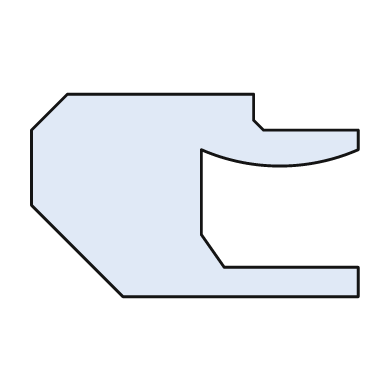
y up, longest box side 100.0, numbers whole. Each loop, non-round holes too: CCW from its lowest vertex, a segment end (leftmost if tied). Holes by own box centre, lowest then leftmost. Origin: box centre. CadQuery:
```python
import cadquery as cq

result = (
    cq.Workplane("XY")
    .moveTo(-22.0, -31.0)
    .lineTo(50.0, -31.0)
    .lineTo(50.0, -22.0)
    .lineTo(9.0, -22.0)
    .lineTo(2.0, -12.0)
    .lineTo(2.0, 14.0)
    .threePointArc((26.0, 9.0), (50.0, 14.0))
    .lineTo(50.0, 20.0)
    .lineTo(21.0, 20.0)
    .lineTo(18.0, 23.0)
    .lineTo(18.0, 31.0)
    .lineTo(-39.0, 31.0)
    .lineTo(-50.0, 20.0)
    .lineTo(-50.0, -3.0)
    .close()
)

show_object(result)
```